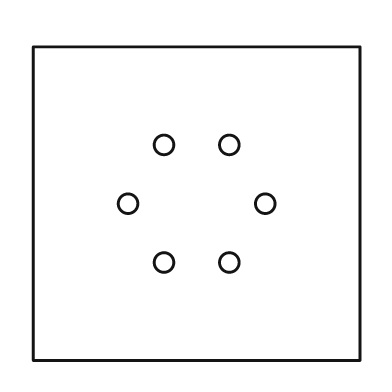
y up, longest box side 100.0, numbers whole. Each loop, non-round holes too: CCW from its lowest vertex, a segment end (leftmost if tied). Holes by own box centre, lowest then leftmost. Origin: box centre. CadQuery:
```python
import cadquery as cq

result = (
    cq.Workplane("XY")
    .moveTo(-50.0, -48.0)
    .lineTo(50.0, -48.0)
    .lineTo(50.0, 48.0)
    .lineTo(-50.0, 48.0)
    .close()
    .moveTo(-10.0, -18.0)
    .circle(3.0)
    .moveTo(10.0, -18.0)
    .circle(3.0)
    .moveTo(-21.0, 0.0)
    .circle(3.0)
    .moveTo(21.0, 0.0)
    .circle(3.0)
    .moveTo(-10.0, 18.0)
    .circle(3.0)
    .moveTo(10.0, 18.0)
    .circle(3.0)
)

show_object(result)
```